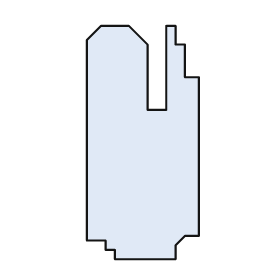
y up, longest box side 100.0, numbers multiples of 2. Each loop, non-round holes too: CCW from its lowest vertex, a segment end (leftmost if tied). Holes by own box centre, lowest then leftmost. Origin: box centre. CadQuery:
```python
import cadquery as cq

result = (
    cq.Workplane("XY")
    .moveTo(-12.0, -50.0)
    .lineTo(14.0, -50.0)
    .lineTo(14.0, -44.0)
    .lineTo(18.0, -40.0)
    .lineTo(24.0, -40.0)
    .lineTo(24.0, 28.0)
    .lineTo(18.0, 28.0)
    .lineTo(18.0, 42.0)
    .lineTo(14.0, 42.0)
    .lineTo(14.0, 50.0)
    .lineTo(10.0, 50.0)
    .lineTo(10.0, 14.0)
    .lineTo(2.0, 14.0)
    .lineTo(2.0, 42.0)
    .lineTo(-6.0, 50.0)
    .lineTo(-18.0, 50.0)
    .lineTo(-24.0, 44.0)
    .lineTo(-24.0, -42.0)
    .lineTo(-16.0, -42.0)
    .lineTo(-16.0, -46.0)
    .lineTo(-12.0, -46.0)
    .close()
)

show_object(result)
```